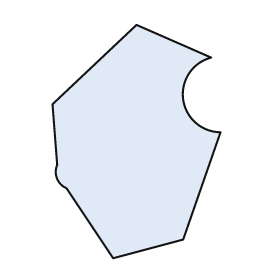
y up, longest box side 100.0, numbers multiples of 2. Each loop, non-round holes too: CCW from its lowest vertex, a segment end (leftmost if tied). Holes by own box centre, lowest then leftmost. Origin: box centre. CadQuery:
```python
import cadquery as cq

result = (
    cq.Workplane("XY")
    .moveTo(-10.0, -50.0)
    .lineTo(20.0, -42.0)
    .lineTo(36.0, 4.0)
    .threePointArc((20.0, 18.0), (32.0, 36.0))
    .lineTo(0.0, 50.0)
    .lineTo(-36.0, 16.0)
    .lineTo(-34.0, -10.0)
    .threePointArc((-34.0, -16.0), (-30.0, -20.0))
    .close()
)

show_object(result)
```